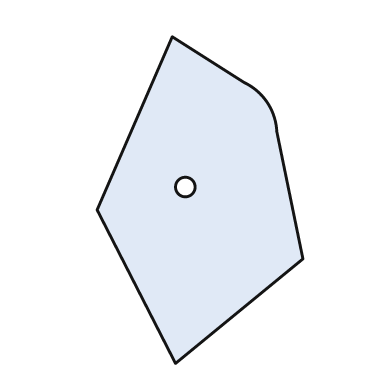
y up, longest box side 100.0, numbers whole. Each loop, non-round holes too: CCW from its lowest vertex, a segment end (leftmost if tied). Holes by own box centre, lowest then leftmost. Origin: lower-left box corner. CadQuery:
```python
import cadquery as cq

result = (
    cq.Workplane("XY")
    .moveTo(24.0, 0.0)
    .lineTo(63.0, 32.0)
    .lineTo(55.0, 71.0)
    .threePointArc((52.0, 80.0), (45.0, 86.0))
    .lineTo(23.0, 100.0)
    .lineTo(0.0, 47.0)
    .close()
    .moveTo(27.0, 54.0)
    .circle(3.0)
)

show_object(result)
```